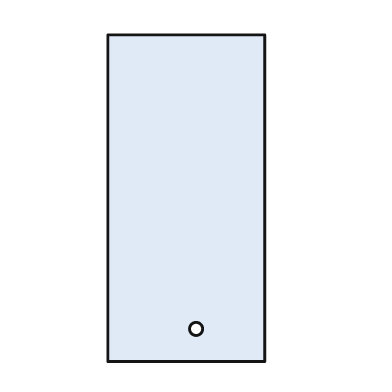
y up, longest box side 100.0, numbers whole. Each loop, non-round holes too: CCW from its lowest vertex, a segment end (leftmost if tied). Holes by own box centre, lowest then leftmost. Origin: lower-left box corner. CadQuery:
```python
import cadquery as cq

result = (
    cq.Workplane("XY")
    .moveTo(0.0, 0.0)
    .lineTo(48.0, 0.0)
    .lineTo(48.0, 100.0)
    .lineTo(0.0, 100.0)
    .close()
    .moveTo(27.0, 10.0)
    .circle(2.0)
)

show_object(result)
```